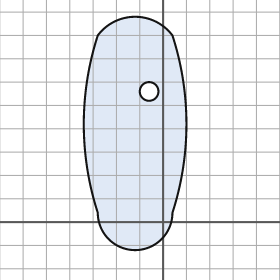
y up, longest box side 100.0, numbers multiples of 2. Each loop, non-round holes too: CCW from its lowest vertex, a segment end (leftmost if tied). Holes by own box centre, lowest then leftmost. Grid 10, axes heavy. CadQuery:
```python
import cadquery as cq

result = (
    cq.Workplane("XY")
    .moveTo(-28.0, 4.0)
    .threePointArc((-12.0, -12.0), (4.0, 4.0))
    .threePointArc((10.0, 42.0), (4.0, 80.0))
    .threePointArc((-12.0, 88.0), (-28.0, 80.0))
    .threePointArc((-34.0, 42.0), (-28.0, 4.0))
    .close()
    .moveTo(-6.0, 56.0)
    .circle(4.0)
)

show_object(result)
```